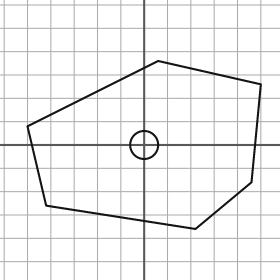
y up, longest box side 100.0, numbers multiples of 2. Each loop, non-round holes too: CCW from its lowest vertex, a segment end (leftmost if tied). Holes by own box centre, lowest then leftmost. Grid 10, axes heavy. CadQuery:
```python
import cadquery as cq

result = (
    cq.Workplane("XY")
    .moveTo(22.0, -36.0)
    .lineTo(46.0, -16.0)
    .lineTo(50.0, 26.0)
    .lineTo(6.0, 36.0)
    .lineTo(-50.0, 8.0)
    .lineTo(-42.0, -26.0)
    .close()
    .moveTo(0.0, 0.0)
    .circle(6.0)
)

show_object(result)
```